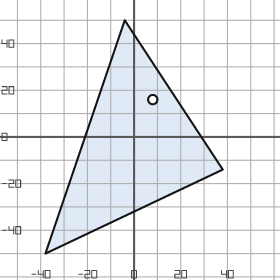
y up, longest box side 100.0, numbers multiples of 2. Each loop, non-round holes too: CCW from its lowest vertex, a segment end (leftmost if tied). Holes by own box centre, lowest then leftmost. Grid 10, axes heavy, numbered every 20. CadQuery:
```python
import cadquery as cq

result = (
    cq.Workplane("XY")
    .moveTo(-38.0, -50.0)
    .lineTo(38.0, -14.0)
    .lineTo(-4.0, 50.0)
    .close()
    .moveTo(8.0, 16.0)
    .circle(2.0)
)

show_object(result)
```